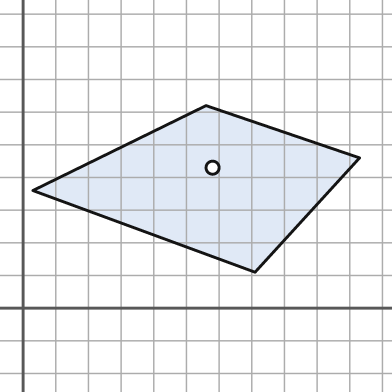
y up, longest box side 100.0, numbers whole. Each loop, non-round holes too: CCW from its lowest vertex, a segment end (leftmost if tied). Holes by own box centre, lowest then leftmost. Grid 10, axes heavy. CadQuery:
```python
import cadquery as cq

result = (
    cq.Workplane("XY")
    .moveTo(71.0, 11.0)
    .lineTo(103.0, 46.0)
    .lineTo(56.0, 62.0)
    .lineTo(3.0, 36.0)
    .close()
    .moveTo(58.0, 43.0)
    .circle(2.0)
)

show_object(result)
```